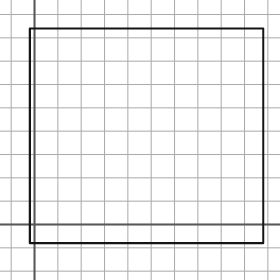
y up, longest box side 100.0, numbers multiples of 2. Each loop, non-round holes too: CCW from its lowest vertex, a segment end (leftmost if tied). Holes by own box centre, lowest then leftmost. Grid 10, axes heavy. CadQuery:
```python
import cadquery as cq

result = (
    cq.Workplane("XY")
    .moveTo(-2.0, -8.0)
    .lineTo(98.0, -8.0)
    .lineTo(98.0, 84.0)
    .lineTo(-2.0, 84.0)
    .close()
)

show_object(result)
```